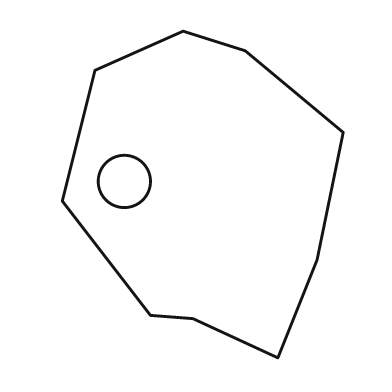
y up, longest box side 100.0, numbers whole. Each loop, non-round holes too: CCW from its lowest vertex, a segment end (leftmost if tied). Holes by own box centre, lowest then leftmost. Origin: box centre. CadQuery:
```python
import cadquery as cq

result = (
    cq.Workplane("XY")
    .moveTo(23.0, -50.0)
    .lineTo(35.0, -20.0)
    .lineTo(43.0, 19.0)
    .lineTo(13.0, 44.0)
    .lineTo(-6.0, 50.0)
    .lineTo(-33.0, 38.0)
    .lineTo(-43.0, -2.0)
    .lineTo(-16.0, -37.0)
    .lineTo(-3.0, -38.0)
    .close()
    .moveTo(-24.0, 4.0)
    .circle(8.0)
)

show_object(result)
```